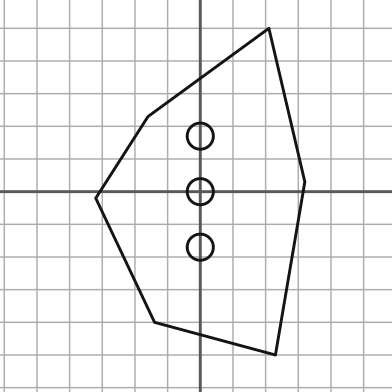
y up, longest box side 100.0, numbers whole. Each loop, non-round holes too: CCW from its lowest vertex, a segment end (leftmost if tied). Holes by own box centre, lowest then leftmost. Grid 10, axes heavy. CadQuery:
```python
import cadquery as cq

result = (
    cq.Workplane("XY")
    .moveTo(23.0, -50.0)
    .lineTo(32.0, 3.0)
    .lineTo(21.0, 50.0)
    .lineTo(-16.0, 23.0)
    .lineTo(-32.0, -2.0)
    .lineTo(-14.0, -40.0)
    .close()
    .moveTo(0.0, -17.0)
    .circle(4.0)
    .moveTo(0.0, 0.0)
    .circle(4.0)
    .moveTo(0.0, 17.0)
    .circle(4.0)
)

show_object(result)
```